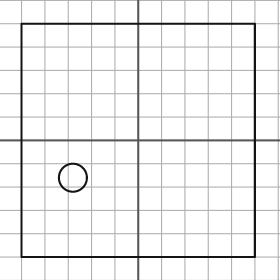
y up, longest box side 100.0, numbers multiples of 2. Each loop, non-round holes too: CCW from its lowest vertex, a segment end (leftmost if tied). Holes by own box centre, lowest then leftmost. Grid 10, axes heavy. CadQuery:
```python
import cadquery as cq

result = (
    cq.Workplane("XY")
    .moveTo(-50.0, -50.0)
    .lineTo(50.0, -50.0)
    .lineTo(50.0, 50.0)
    .lineTo(-50.0, 50.0)
    .close()
    .moveTo(-28.0, -16.0)
    .circle(6.0)
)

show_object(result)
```